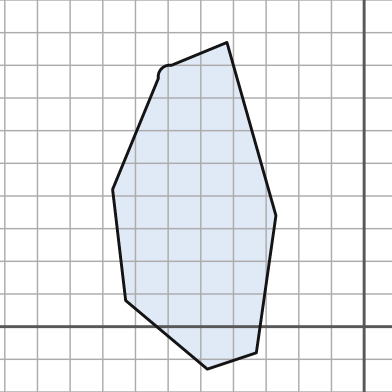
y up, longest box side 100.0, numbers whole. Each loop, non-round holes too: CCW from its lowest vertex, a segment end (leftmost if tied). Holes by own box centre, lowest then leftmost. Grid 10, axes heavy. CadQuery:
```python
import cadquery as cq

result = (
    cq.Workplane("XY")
    .moveTo(-48.0, -13.0)
    .lineTo(-33.0, -8.0)
    .lineTo(-27.0, 34.0)
    .lineTo(-42.0, 87.0)
    .lineTo(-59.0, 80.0)
    .threePointArc((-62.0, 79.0), (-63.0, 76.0))
    .lineTo(-77.0, 42.0)
    .lineTo(-73.0, 8.0)
    .close()
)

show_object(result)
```